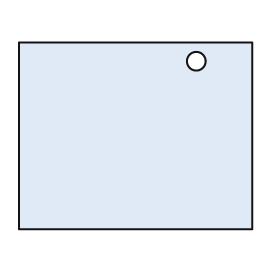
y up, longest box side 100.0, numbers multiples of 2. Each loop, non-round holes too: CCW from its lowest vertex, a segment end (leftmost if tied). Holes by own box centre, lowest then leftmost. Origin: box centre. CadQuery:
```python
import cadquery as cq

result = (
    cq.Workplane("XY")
    .moveTo(-50.0, -40.0)
    .lineTo(50.0, -40.0)
    .lineTo(50.0, 40.0)
    .lineTo(-50.0, 40.0)
    .close()
    .moveTo(26.0, 32.0)
    .circle(4.0)
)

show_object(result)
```